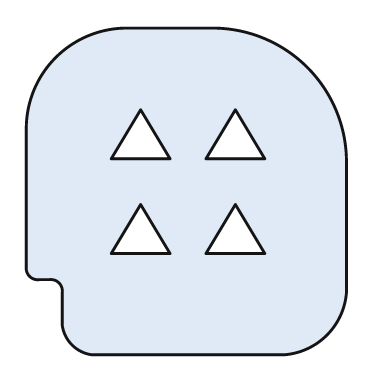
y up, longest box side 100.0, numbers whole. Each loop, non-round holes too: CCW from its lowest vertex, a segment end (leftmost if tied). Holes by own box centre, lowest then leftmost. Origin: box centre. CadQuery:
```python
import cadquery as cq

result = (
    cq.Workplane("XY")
    .moveTo(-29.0, -50.0)
    .lineTo(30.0, -50.0)
    .threePointArc((43.0, -44.0), (49.0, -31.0))
    .lineTo(49.0, 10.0)
    .threePointArc((37.0, 38.0), (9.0, 50.0))
    .lineTo(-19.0, 50.0)
    .threePointArc((-40.0, 41.0), (-49.0, 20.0))
    .lineTo(-49.0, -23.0)
    .threePointArc((-48.0, -26.0), (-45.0, -27.0))
    .lineTo(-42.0, -27.0)
    .threePointArc((-39.0, -28.0), (-38.0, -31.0))
    .lineTo(-38.0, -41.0)
    .threePointArc((-35.0, -47.0), (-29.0, -50.0))
    .close()
    .moveTo(-23.0, -19.0)
    .lineTo(-5.0, -19.0)
    .lineTo(-14.0, -4.0)
    .close()
    .moveTo(6.0, -19.0)
    .lineTo(24.0, -19.0)
    .lineTo(15.0, -4.0)
    .close()
    .moveTo(-23.0, 10.0)
    .lineTo(-5.0, 10.0)
    .lineTo(-14.0, 25.0)
    .close()
    .moveTo(6.0, 10.0)
    .lineTo(24.0, 10.0)
    .lineTo(15.0, 25.0)
    .close()
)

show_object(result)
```